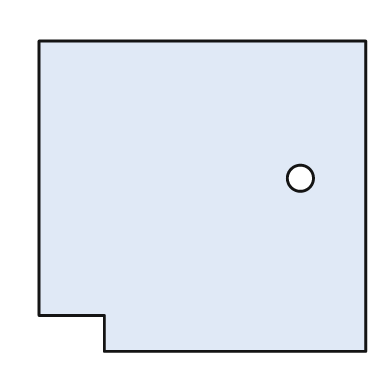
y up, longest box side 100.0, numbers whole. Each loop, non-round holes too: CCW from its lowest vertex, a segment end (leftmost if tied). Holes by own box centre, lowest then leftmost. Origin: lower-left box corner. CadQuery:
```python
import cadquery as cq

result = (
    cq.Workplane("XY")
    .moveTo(20.0, 0.0)
    .lineTo(100.0, 0.0)
    .lineTo(100.0, 95.0)
    .lineTo(0.0, 95.0)
    .lineTo(0.0, 11.0)
    .lineTo(20.0, 11.0)
    .close()
    .moveTo(80.0, 53.0)
    .circle(4.0)
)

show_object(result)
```